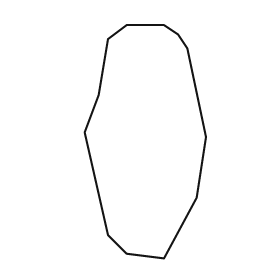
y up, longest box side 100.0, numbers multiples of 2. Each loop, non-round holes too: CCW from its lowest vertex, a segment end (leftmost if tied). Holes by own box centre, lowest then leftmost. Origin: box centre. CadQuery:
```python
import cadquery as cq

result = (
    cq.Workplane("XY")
    .moveTo(8.0, -50.0)
    .lineTo(22.0, -24.0)
    .lineTo(26.0, 2.0)
    .lineTo(18.0, 40.0)
    .lineTo(14.0, 46.0)
    .lineTo(8.0, 50.0)
    .lineTo(-8.0, 50.0)
    .lineTo(-16.0, 44.0)
    .lineTo(-20.0, 20.0)
    .lineTo(-26.0, 4.0)
    .lineTo(-16.0, -40.0)
    .lineTo(-8.0, -48.0)
    .close()
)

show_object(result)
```